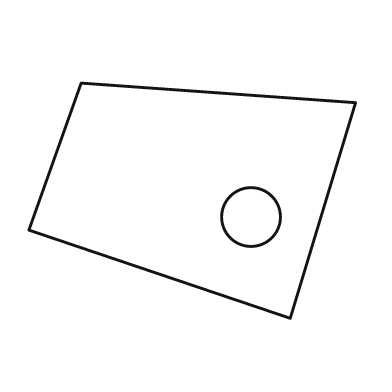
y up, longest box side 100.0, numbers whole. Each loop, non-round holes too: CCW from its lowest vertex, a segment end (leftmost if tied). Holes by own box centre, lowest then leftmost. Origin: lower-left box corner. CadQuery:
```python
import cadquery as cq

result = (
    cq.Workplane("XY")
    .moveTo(80.0, 0.0)
    .lineTo(100.0, 66.0)
    .lineTo(16.0, 72.0)
    .lineTo(0.0, 27.0)
    .close()
    .moveTo(68.0, 31.0)
    .circle(9.0)
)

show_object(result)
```